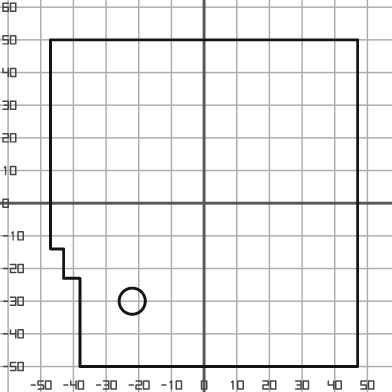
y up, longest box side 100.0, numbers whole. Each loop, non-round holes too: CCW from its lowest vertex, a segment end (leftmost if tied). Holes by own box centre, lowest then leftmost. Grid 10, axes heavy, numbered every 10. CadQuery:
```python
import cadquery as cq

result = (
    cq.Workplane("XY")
    .moveTo(-38.0, -50.0)
    .lineTo(47.0, -50.0)
    .lineTo(47.0, 50.0)
    .lineTo(-47.0, 50.0)
    .lineTo(-47.0, -14.0)
    .lineTo(-43.0, -14.0)
    .lineTo(-43.0, -23.0)
    .lineTo(-38.0, -23.0)
    .close()
    .moveTo(-22.0, -30.0)
    .circle(4.0)
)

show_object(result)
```